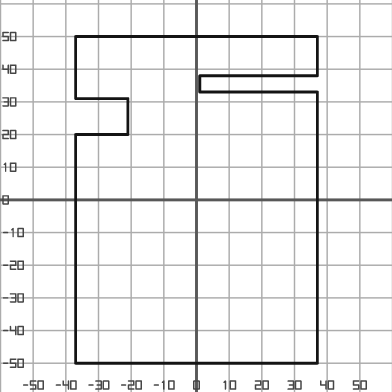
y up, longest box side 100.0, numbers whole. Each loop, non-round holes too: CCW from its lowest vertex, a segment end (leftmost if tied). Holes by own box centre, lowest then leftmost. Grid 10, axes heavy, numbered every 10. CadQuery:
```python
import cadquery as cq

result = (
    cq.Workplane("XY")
    .moveTo(-37.0, -50.0)
    .lineTo(37.0, -50.0)
    .lineTo(37.0, 33.0)
    .lineTo(1.0, 33.0)
    .lineTo(1.0, 38.0)
    .lineTo(37.0, 38.0)
    .lineTo(37.0, 50.0)
    .lineTo(-37.0, 50.0)
    .lineTo(-37.0, 31.0)
    .lineTo(-21.0, 31.0)
    .lineTo(-21.0, 20.0)
    .lineTo(-37.0, 20.0)
    .close()
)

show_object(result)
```